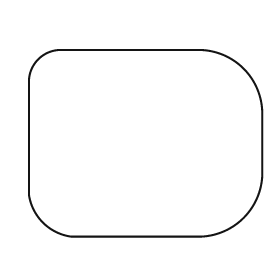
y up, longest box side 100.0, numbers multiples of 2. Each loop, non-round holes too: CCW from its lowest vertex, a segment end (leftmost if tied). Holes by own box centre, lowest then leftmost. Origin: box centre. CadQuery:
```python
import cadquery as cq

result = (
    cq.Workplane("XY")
    .moveTo(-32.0, -40.0)
    .lineTo(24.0, -40.0)
    .threePointArc((42.0, -32.0), (50.0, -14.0))
    .lineTo(50.0, 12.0)
    .threePointArc((42.0, 32.0), (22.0, 40.0))
    .lineTo(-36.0, 40.0)
    .threePointArc((-46.0, 36.0), (-50.0, 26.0))
    .lineTo(-50.0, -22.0)
    .threePointArc((-44.0, -34.0), (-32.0, -40.0))
    .close()
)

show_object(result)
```